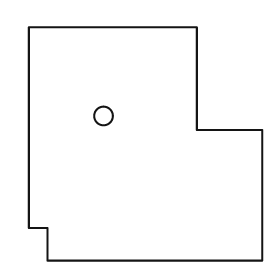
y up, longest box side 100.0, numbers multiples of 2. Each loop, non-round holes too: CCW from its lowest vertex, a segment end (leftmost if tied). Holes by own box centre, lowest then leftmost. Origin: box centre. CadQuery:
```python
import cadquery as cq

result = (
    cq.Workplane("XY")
    .moveTo(-42.0, -50.0)
    .lineTo(50.0, -50.0)
    .lineTo(50.0, 6.0)
    .lineTo(22.0, 6.0)
    .lineTo(22.0, 50.0)
    .lineTo(-50.0, 50.0)
    .lineTo(-50.0, -36.0)
    .lineTo(-42.0, -36.0)
    .close()
    .moveTo(-18.0, 12.0)
    .circle(4.0)
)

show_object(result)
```